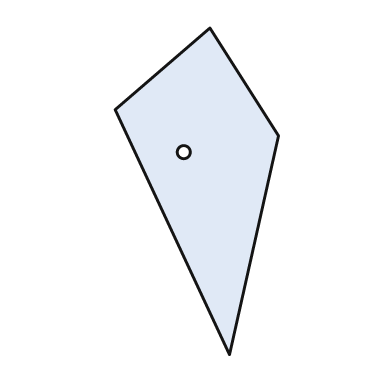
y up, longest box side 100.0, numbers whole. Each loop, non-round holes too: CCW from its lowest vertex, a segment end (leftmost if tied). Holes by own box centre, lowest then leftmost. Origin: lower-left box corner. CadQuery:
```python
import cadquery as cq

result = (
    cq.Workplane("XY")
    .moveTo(35.0, 0.0)
    .lineTo(50.0, 67.0)
    .lineTo(29.0, 100.0)
    .lineTo(0.0, 75.0)
    .close()
    .moveTo(21.0, 62.0)
    .circle(2.0)
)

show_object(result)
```